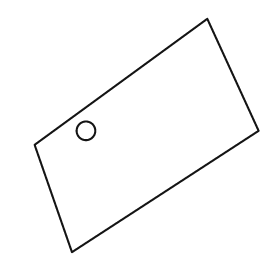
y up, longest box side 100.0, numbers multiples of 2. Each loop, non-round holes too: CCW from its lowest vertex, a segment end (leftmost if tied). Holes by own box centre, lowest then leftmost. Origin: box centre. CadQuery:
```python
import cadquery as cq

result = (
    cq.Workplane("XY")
    .moveTo(-32.0, -50.0)
    .lineTo(48.0, 2.0)
    .lineTo(26.0, 50.0)
    .lineTo(-48.0, -4.0)
    .close()
    .moveTo(-26.0, 2.0)
    .circle(4.0)
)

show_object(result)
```